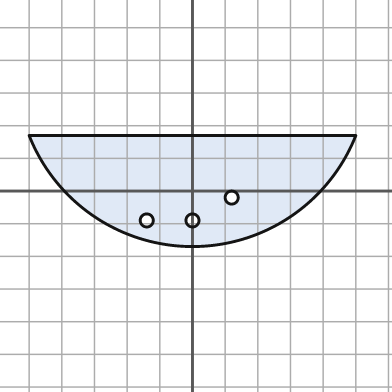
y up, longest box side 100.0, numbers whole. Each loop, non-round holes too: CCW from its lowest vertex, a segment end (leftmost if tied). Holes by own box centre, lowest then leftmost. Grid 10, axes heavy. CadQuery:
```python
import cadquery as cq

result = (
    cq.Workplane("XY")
    .moveTo(-50.0, 17.0)
    .threePointArc((0.0, -17.0), (50.0, 17.0))
    .close()
    .moveTo(-14.0, -9.0)
    .circle(2.0)
    .moveTo(0.0, -9.0)
    .circle(2.0)
    .moveTo(12.0, -2.0)
    .circle(2.0)
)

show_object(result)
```